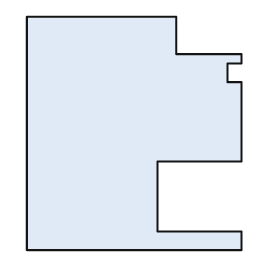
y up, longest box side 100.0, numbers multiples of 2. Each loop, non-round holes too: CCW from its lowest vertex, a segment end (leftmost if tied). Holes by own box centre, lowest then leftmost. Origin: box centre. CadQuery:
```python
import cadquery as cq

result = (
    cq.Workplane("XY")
    .moveTo(-46.0, -50.0)
    .lineTo(46.0, -50.0)
    .lineTo(46.0, -42.0)
    .lineTo(10.0, -42.0)
    .lineTo(10.0, -12.0)
    .lineTo(46.0, -12.0)
    .lineTo(46.0, 22.0)
    .lineTo(40.0, 22.0)
    .lineTo(40.0, 30.0)
    .lineTo(46.0, 30.0)
    .lineTo(46.0, 34.0)
    .lineTo(18.0, 34.0)
    .lineTo(18.0, 50.0)
    .lineTo(-46.0, 50.0)
    .close()
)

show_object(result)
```